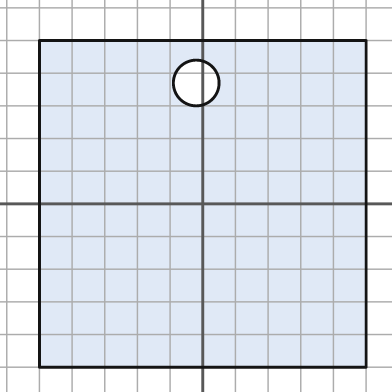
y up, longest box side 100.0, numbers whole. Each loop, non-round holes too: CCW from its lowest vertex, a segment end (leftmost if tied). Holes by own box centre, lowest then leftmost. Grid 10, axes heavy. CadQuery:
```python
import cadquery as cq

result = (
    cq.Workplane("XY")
    .moveTo(-50.0, -50.0)
    .lineTo(50.0, -50.0)
    .lineTo(50.0, 50.0)
    .lineTo(-50.0, 50.0)
    .close()
    .moveTo(-2.0, 37.0)
    .circle(7.0)
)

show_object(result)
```